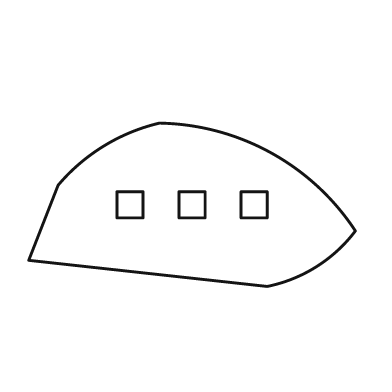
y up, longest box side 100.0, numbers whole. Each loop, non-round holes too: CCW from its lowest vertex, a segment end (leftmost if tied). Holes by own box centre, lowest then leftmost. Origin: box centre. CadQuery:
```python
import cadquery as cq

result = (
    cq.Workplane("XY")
    .moveTo(23.0, -25.0)
    .threePointArc((38.0, -19.0), (50.0, -8.0))
    .threePointArc((24.0, 16.0), (-10.0, 25.0))
    .threePointArc((-27.0, 18.0), (-41.0, 6.0))
    .lineTo(-50.0, -17.0)
    .close()
    .moveTo(-23.0, -4.0)
    .lineTo(-15.0, -4.0)
    .lineTo(-15.0, 4.0)
    .lineTo(-23.0, 4.0)
    .close()
    .moveTo(-4.0, -4.0)
    .lineTo(4.0, -4.0)
    .lineTo(4.0, 4.0)
    .lineTo(-4.0, 4.0)
    .close()
    .moveTo(15.0, -4.0)
    .lineTo(23.0, -4.0)
    .lineTo(23.0, 4.0)
    .lineTo(15.0, 4.0)
    .close()
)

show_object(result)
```